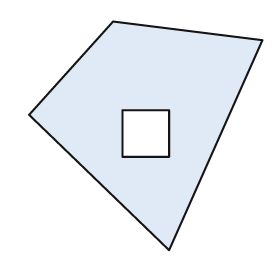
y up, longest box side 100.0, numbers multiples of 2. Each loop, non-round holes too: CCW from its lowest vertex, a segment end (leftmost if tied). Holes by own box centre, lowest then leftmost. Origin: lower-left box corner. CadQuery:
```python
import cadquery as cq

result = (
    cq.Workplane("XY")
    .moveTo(60.0, 0.0)
    .lineTo(100.0, 90.0)
    .lineTo(36.0, 98.0)
    .lineTo(0.0, 58.0)
    .close()
    .moveTo(40.0, 40.0)
    .lineTo(60.0, 40.0)
    .lineTo(60.0, 60.0)
    .lineTo(40.0, 60.0)
    .close()
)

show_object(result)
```